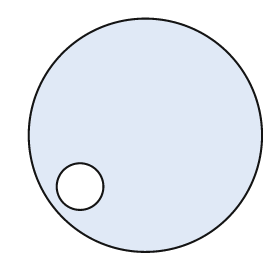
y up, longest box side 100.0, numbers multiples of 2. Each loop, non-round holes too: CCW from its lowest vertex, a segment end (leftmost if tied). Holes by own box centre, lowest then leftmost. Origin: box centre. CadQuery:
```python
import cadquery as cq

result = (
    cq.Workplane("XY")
    .moveTo(0.0, 0.0)
    .circle(50.0)
    .moveTo(-28.0, -22.0)
    .circle(10.0)
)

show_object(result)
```